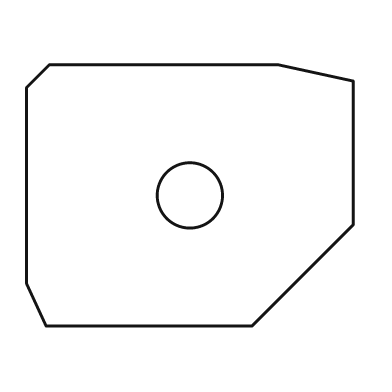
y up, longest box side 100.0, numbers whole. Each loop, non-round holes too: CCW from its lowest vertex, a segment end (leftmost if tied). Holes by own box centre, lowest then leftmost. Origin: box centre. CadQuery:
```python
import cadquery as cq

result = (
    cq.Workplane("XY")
    .moveTo(-44.0, -40.0)
    .lineTo(19.0, -40.0)
    .lineTo(50.0, -9.0)
    .lineTo(50.0, 35.0)
    .lineTo(27.0, 40.0)
    .lineTo(-43.0, 40.0)
    .lineTo(-50.0, 33.0)
    .lineTo(-50.0, -27.0)
    .close()
    .moveTo(0.0, 0.0)
    .circle(10.0)
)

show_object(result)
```